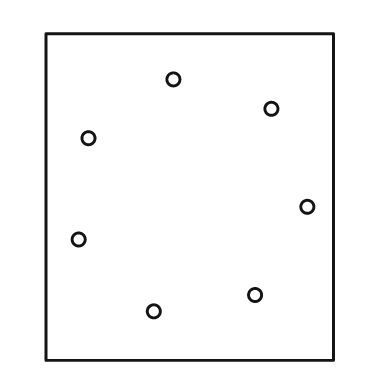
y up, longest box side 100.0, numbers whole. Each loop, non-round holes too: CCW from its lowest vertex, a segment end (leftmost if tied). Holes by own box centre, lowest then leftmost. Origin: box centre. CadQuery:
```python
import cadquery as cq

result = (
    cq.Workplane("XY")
    .moveTo(-44.0, -50.0)
    .lineTo(44.0, -50.0)
    .lineTo(44.0, 50.0)
    .lineTo(-44.0, 50.0)
    .close()
    .moveTo(-11.0, -35.0)
    .circle(2.0)
    .moveTo(20.0, -30.0)
    .circle(2.0)
    .moveTo(-34.0, -13.0)
    .circle(2.0)
    .moveTo(36.0, -3.0)
    .circle(2.0)
    .moveTo(-31.0, 18.0)
    .circle(2.0)
    .moveTo(25.0, 27.0)
    .circle(2.0)
    .moveTo(-5.0, 36.0)
    .circle(2.0)
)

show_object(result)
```